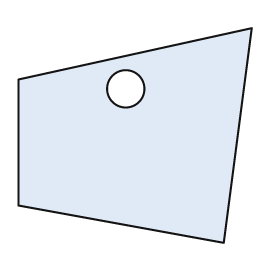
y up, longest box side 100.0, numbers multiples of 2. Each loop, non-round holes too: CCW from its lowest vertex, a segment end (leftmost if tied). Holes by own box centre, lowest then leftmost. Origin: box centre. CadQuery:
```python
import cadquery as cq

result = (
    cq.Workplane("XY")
    .moveTo(38.0, -46.0)
    .lineTo(50.0, 46.0)
    .lineTo(-50.0, 24.0)
    .lineTo(-50.0, -30.0)
    .close()
    .moveTo(-4.0, 20.0)
    .circle(8.0)
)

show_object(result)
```